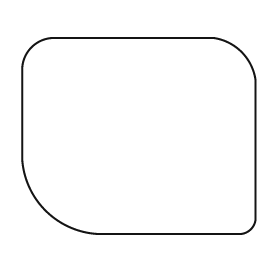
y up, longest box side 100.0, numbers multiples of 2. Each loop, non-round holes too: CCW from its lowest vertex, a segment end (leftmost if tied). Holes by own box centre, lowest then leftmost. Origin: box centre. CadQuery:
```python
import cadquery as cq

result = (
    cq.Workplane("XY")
    .moveTo(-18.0, -42.0)
    .lineTo(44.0, -42.0)
    .threePointArc((48.0, -40.0), (50.0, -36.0))
    .lineTo(50.0, 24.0)
    .threePointArc((44.0, 36.0), (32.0, 42.0))
    .lineTo(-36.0, 42.0)
    .threePointArc((-46.0, 38.0), (-50.0, 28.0))
    .lineTo(-50.0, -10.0)
    .threePointArc((-40.0, -32.0), (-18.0, -42.0))
    .close()
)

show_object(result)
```